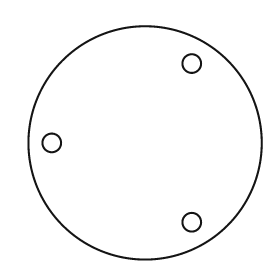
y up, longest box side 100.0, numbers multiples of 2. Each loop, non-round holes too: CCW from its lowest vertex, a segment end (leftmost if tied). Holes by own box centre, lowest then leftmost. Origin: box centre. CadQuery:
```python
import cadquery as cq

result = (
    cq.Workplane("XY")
    .moveTo(0.0, 0.0)
    .circle(50.0)
    .moveTo(20.0, -34.0)
    .circle(4.0)
    .moveTo(-40.0, 0.0)
    .circle(4.0)
    .moveTo(20.0, 34.0)
    .circle(4.0)
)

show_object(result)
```